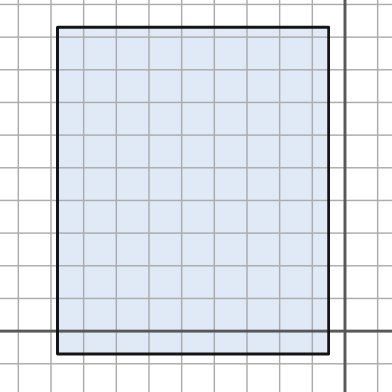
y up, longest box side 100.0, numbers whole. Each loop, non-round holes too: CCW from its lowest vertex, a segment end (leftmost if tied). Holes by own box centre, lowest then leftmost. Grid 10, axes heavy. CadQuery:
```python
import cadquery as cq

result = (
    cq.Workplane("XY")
    .moveTo(-88.0, -7.0)
    .lineTo(-5.0, -7.0)
    .lineTo(-5.0, 93.0)
    .lineTo(-88.0, 93.0)
    .close()
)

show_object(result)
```